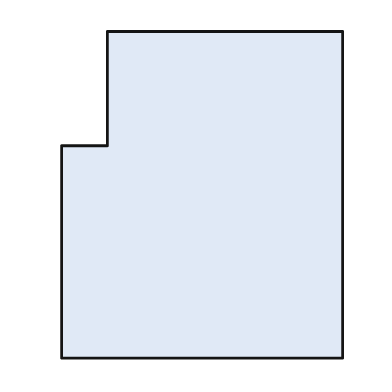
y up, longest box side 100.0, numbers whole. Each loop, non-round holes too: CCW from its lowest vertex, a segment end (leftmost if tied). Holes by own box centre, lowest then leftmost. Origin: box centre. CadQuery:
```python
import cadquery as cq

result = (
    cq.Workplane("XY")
    .moveTo(-43.0, -50.0)
    .lineTo(43.0, -50.0)
    .lineTo(43.0, 50.0)
    .lineTo(-29.0, 50.0)
    .lineTo(-29.0, 15.0)
    .lineTo(-43.0, 15.0)
    .close()
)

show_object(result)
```